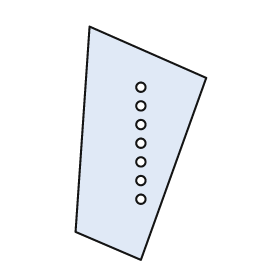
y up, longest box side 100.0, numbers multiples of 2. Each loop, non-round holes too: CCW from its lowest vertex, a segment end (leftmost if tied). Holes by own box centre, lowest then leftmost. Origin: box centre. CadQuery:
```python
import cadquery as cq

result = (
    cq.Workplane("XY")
    .moveTo(0.0, -50.0)
    .lineTo(28.0, 28.0)
    .lineTo(-22.0, 50.0)
    .lineTo(-28.0, -38.0)
    .close()
    .moveTo(0.0, -24.0)
    .circle(2.0)
    .moveTo(0.0, -16.0)
    .circle(2.0)
    .moveTo(0.0, -8.0)
    .circle(2.0)
    .moveTo(0.0, 0.0)
    .circle(2.0)
    .moveTo(0.0, 8.0)
    .circle(2.0)
    .moveTo(0.0, 16.0)
    .circle(2.0)
    .moveTo(0.0, 24.0)
    .circle(2.0)
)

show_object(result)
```